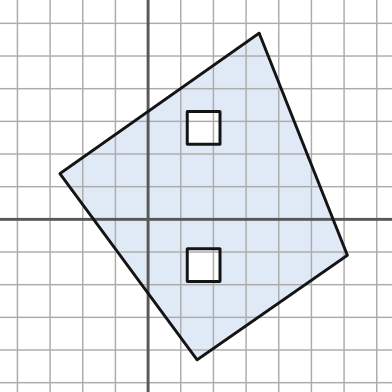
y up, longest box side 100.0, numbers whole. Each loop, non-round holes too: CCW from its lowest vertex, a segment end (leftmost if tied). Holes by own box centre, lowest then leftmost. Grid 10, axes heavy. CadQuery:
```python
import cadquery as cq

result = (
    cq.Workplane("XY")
    .moveTo(15.0, -43.0)
    .lineTo(61.0, -11.0)
    .lineTo(34.0, 57.0)
    .lineTo(-27.0, 14.0)
    .close()
    .moveTo(12.0, -19.0)
    .lineTo(22.0, -19.0)
    .lineTo(22.0, -9.0)
    .lineTo(12.0, -9.0)
    .close()
    .moveTo(12.0, 23.0)
    .lineTo(22.0, 23.0)
    .lineTo(22.0, 33.0)
    .lineTo(12.0, 33.0)
    .close()
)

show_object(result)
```